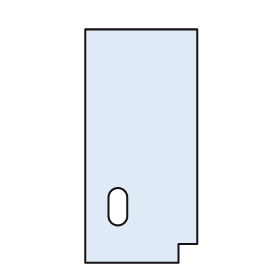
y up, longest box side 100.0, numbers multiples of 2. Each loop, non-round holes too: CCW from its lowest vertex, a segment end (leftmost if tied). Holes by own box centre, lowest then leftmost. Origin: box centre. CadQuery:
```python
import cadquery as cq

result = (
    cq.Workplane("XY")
    .moveTo(-24.0, -50.0)
    .lineTo(16.0, -50.0)
    .lineTo(16.0, -42.0)
    .lineTo(24.0, -42.0)
    .lineTo(24.0, 50.0)
    .lineTo(-24.0, 50.0)
    .close()
    .moveTo(-14.0, -30.0)
    .threePointArc((-10.0, -34.0), (-6.0, -30.0))
    .lineTo(-6.0, -22.0)
    .threePointArc((-10.0, -18.0), (-14.0, -22.0))
    .close()
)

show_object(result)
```